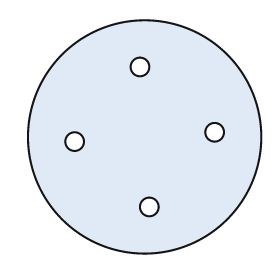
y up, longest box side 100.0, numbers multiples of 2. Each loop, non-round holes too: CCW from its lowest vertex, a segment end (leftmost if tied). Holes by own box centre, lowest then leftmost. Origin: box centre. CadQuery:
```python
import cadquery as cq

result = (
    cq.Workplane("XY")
    .moveTo(0.0, 0.0)
    .circle(50.0)
    .moveTo(2.0, -30.0)
    .circle(4.0)
    .moveTo(-30.0, -2.0)
    .circle(4.0)
    .moveTo(30.0, 2.0)
    .circle(4.0)
    .moveTo(-2.0, 30.0)
    .circle(4.0)
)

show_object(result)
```